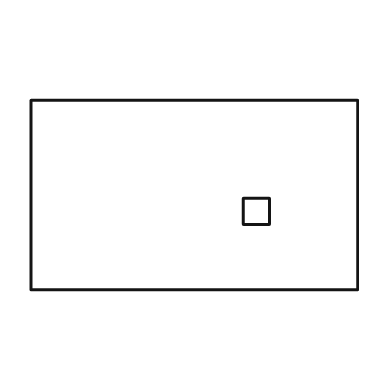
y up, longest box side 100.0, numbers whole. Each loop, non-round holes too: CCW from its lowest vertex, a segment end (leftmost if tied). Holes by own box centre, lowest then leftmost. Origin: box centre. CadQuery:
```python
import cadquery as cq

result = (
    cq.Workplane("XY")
    .moveTo(-50.0, -29.0)
    .lineTo(50.0, -29.0)
    .lineTo(50.0, 29.0)
    .lineTo(-50.0, 29.0)
    .close()
    .moveTo(15.0, -9.0)
    .lineTo(23.0, -9.0)
    .lineTo(23.0, -1.0)
    .lineTo(15.0, -1.0)
    .close()
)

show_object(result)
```